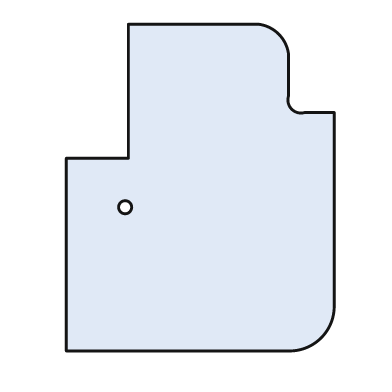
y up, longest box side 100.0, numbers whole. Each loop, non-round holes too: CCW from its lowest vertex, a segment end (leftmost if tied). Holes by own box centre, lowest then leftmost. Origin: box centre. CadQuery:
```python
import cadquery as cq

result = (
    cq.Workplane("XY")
    .moveTo(-41.0, -50.0)
    .lineTo(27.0, -50.0)
    .threePointArc((37.0, -46.0), (41.0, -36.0))
    .lineTo(41.0, 23.0)
    .lineTo(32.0, 23.0)
    .threePointArc((28.0, 24.0), (27.0, 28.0))
    .lineTo(27.0, 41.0)
    .threePointArc((24.0, 47.0), (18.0, 50.0))
    .lineTo(-22.0, 50.0)
    .lineTo(-22.0, 9.0)
    .lineTo(-41.0, 9.0)
    .close()
    .moveTo(-23.0, -6.0)
    .circle(2.0)
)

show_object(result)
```